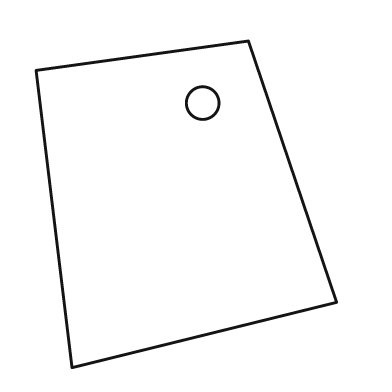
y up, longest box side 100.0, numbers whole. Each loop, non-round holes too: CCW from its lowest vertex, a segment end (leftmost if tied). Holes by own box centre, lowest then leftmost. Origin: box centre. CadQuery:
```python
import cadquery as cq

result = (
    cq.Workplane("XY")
    .moveTo(-35.0, -50.0)
    .lineTo(46.0, -30.0)
    .lineTo(19.0, 50.0)
    .lineTo(-46.0, 41.0)
    .close()
    .moveTo(5.0, 31.0)
    .circle(5.0)
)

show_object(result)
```